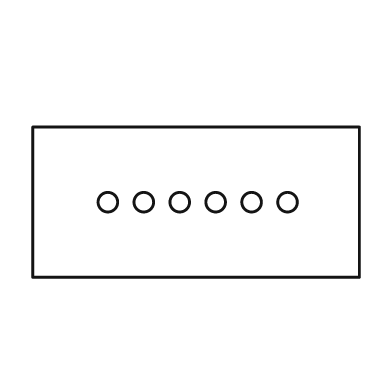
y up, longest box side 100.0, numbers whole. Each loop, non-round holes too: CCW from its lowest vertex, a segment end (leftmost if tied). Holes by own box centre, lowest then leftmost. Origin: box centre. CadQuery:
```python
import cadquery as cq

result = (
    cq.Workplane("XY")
    .moveTo(-50.0, -23.0)
    .lineTo(50.0, -23.0)
    .lineTo(50.0, 23.0)
    .lineTo(-50.0, 23.0)
    .close()
    .moveTo(-27.0, 0.0)
    .circle(3.0)
    .moveTo(-16.0, 0.0)
    .circle(3.0)
    .moveTo(-5.0, 0.0)
    .circle(3.0)
    .moveTo(6.0, 0.0)
    .circle(3.0)
    .moveTo(17.0, 0.0)
    .circle(3.0)
    .moveTo(28.0, 0.0)
    .circle(3.0)
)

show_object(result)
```